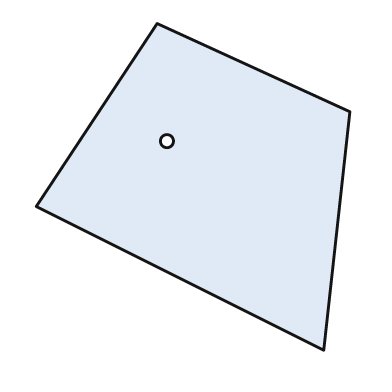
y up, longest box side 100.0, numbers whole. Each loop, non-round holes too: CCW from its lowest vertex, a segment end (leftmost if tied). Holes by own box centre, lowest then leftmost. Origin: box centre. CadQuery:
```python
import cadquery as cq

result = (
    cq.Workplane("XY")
    .moveTo(40.0, -50.0)
    .lineTo(48.0, 23.0)
    .lineTo(-11.0, 50.0)
    .lineTo(-48.0, -6.0)
    .close()
    .moveTo(-8.0, 14.0)
    .circle(2.0)
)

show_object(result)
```